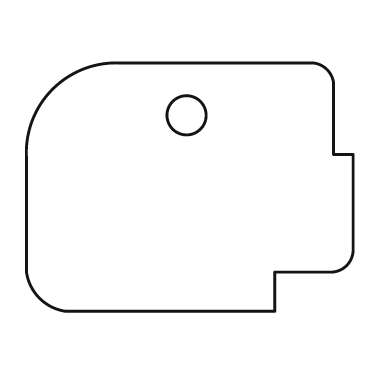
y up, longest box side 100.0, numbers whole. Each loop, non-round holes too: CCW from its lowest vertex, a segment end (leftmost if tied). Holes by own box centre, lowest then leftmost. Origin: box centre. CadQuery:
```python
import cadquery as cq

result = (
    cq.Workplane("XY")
    .moveTo(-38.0, -38.0)
    .lineTo(26.0, -38.0)
    .lineTo(26.0, -26.0)
    .lineTo(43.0, -26.0)
    .threePointArc((48.0, -24.0), (50.0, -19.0))
    .lineTo(50.0, 10.0)
    .lineTo(44.0, 10.0)
    .lineTo(44.0, 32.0)
    .threePointArc((42.0, 36.0), (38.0, 38.0))
    .lineTo(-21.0, 38.0)
    .threePointArc((-42.0, 30.0), (-50.0, 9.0))
    .lineTo(-50.0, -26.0)
    .threePointArc((-46.0, -34.0), (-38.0, -38.0))
    .close()
    .moveTo(-1.0, 22.0)
    .circle(6.0)
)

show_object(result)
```